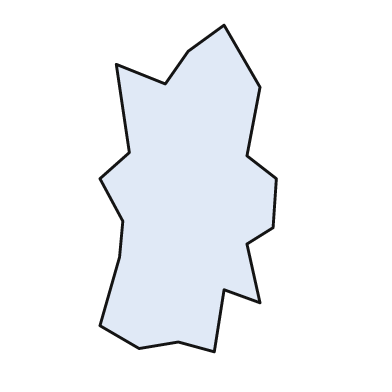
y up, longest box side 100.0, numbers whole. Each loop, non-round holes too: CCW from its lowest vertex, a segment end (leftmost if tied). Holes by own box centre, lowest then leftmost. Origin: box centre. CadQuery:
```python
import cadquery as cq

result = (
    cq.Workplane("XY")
    .moveTo(8.0, -50.0)
    .lineTo(11.0, -31.0)
    .lineTo(22.0, -35.0)
    .lineTo(18.0, -17.0)
    .lineTo(26.0, -12.0)
    .lineTo(27.0, 3.0)
    .lineTo(18.0, 10.0)
    .lineTo(22.0, 31.0)
    .lineTo(11.0, 50.0)
    .lineTo(0.0, 42.0)
    .lineTo(-7.0, 32.0)
    .lineTo(-22.0, 38.0)
    .lineTo(-18.0, 11.0)
    .lineTo(-27.0, 3.0)
    .lineTo(-20.0, -10.0)
    .lineTo(-21.0, -21.0)
    .lineTo(-27.0, -42.0)
    .lineTo(-15.0, -49.0)
    .lineTo(-3.0, -47.0)
    .close()
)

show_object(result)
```